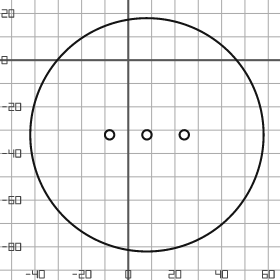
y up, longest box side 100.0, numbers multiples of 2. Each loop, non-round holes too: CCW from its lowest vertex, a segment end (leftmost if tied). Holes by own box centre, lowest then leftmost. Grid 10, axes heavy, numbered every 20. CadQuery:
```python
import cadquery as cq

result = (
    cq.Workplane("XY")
    .moveTo(8.0, -32.0)
    .circle(50.0)
    .moveTo(-8.0, -32.0)
    .circle(2.0)
    .moveTo(8.0, -32.0)
    .circle(2.0)
    .moveTo(24.0, -32.0)
    .circle(2.0)
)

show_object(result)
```